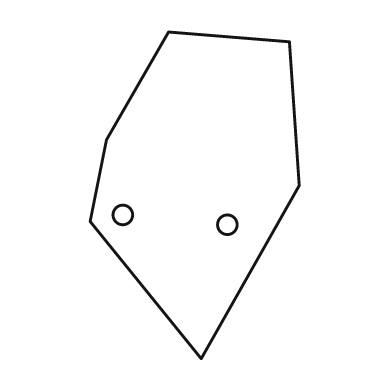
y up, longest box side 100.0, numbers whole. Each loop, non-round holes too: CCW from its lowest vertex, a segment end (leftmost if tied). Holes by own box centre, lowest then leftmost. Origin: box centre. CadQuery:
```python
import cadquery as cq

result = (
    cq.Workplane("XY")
    .moveTo(2.0, -50.0)
    .lineTo(32.0, 3.0)
    .lineTo(29.0, 47.0)
    .lineTo(-8.0, 50.0)
    .lineTo(-27.0, 17.0)
    .lineTo(-32.0, -8.0)
    .close()
    .moveTo(10.0, -9.0)
    .circle(3.0)
    .moveTo(-22.0, -6.0)
    .circle(3.0)
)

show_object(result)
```